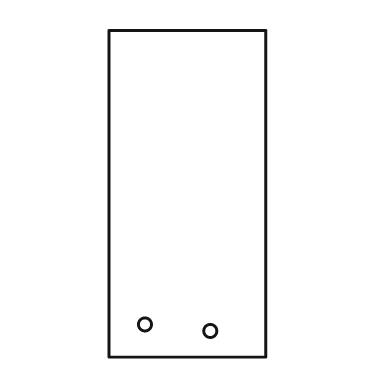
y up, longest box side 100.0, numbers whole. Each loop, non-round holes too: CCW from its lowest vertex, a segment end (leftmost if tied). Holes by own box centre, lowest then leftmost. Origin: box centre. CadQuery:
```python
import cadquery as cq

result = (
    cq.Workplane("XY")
    .moveTo(-24.0, -50.0)
    .lineTo(24.0, -50.0)
    .lineTo(24.0, 50.0)
    .lineTo(-24.0, 50.0)
    .close()
    .moveTo(7.0, -42.0)
    .circle(2.0)
    .moveTo(-13.0, -40.0)
    .circle(2.0)
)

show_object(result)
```